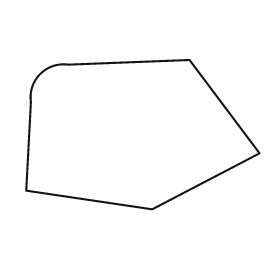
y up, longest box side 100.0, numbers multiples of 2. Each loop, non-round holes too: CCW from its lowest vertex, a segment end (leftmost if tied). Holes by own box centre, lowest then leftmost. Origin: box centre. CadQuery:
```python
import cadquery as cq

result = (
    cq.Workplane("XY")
    .moveTo(4.0, -32.0)
    .lineTo(50.0, -8.0)
    .lineTo(20.0, 32.0)
    .lineTo(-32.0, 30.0)
    .threePointArc((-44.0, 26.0), (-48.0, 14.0))
    .lineTo(-50.0, -24.0)
    .close()
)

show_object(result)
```